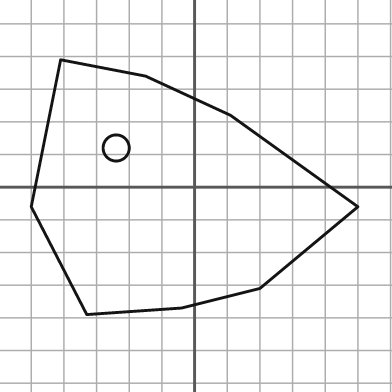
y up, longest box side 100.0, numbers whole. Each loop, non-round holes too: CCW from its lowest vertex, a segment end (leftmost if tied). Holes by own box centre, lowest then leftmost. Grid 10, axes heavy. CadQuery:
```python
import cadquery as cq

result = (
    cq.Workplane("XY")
    .moveTo(-33.0, -39.0)
    .lineTo(-4.0, -37.0)
    .lineTo(20.0, -31.0)
    .lineTo(50.0, -6.0)
    .lineTo(11.0, 22.0)
    .lineTo(-15.0, 34.0)
    .lineTo(-41.0, 39.0)
    .lineTo(-50.0, -6.0)
    .close()
    .moveTo(-24.0, 12.0)
    .circle(4.0)
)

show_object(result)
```